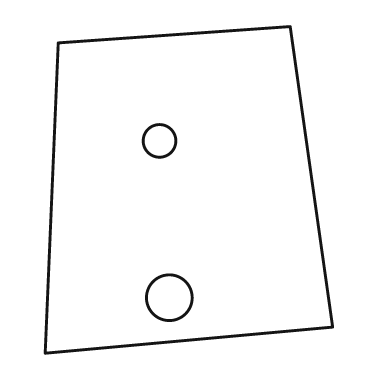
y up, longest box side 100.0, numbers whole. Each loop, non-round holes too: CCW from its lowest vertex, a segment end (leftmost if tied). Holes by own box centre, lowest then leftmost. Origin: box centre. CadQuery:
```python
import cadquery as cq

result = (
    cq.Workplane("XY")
    .moveTo(-44.0, -50.0)
    .lineTo(44.0, -42.0)
    .lineTo(31.0, 50.0)
    .lineTo(-40.0, 45.0)
    .close()
    .moveTo(-6.0, -33.0)
    .circle(7.0)
    .moveTo(-9.0, 15.0)
    .circle(5.0)
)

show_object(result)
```